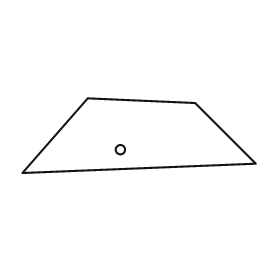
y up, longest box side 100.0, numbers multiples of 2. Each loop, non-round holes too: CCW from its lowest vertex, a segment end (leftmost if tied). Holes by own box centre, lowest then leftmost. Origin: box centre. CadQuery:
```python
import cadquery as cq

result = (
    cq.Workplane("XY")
    .moveTo(-50.0, -16.0)
    .lineTo(50.0, -12.0)
    .lineTo(24.0, 14.0)
    .lineTo(-22.0, 16.0)
    .close()
    .moveTo(-8.0, -6.0)
    .circle(2.0)
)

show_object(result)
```